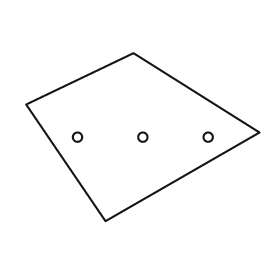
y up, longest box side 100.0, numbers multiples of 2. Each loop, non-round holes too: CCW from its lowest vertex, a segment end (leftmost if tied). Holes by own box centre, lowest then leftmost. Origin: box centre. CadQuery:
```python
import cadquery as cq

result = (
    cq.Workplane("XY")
    .moveTo(-16.0, -36.0)
    .lineTo(50.0, 2.0)
    .lineTo(-4.0, 36.0)
    .lineTo(-50.0, 14.0)
    .close()
    .moveTo(-28.0, 0.0)
    .circle(2.0)
    .moveTo(0.0, 0.0)
    .circle(2.0)
    .moveTo(28.0, 0.0)
    .circle(2.0)
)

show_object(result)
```